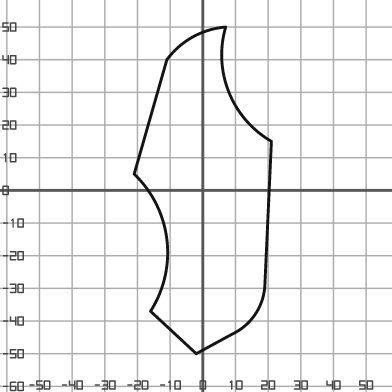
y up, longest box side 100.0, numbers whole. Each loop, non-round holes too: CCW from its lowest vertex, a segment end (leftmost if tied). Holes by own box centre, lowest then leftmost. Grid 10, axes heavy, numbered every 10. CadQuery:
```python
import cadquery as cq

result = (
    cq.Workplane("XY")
    .moveTo(-2.0, -50.0)
    .lineTo(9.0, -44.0)
    .threePointArc((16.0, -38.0), (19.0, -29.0))
    .lineTo(21.0, 15.0)
    .threePointArc((8.0, 30.0), (7.0, 50.0))
    .threePointArc((-3.0, 47.0), (-11.0, 40.0))
    .lineTo(-21.0, 5.0)
    .threePointArc((-11.0, -15.0), (-16.0, -37.0))
    .close()
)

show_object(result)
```